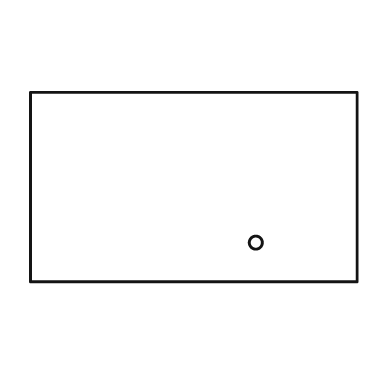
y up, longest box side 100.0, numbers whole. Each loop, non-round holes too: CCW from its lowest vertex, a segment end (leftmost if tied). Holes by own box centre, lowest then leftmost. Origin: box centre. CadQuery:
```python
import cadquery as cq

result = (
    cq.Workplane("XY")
    .moveTo(-50.0, -29.0)
    .lineTo(50.0, -29.0)
    .lineTo(50.0, 29.0)
    .lineTo(-50.0, 29.0)
    .close()
    .moveTo(19.0, -17.0)
    .circle(2.0)
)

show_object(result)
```